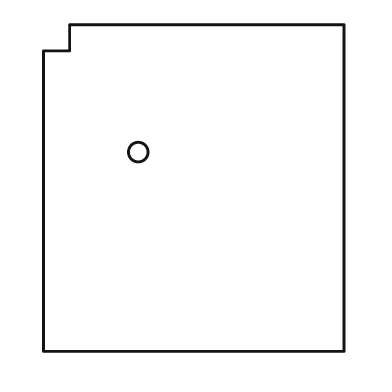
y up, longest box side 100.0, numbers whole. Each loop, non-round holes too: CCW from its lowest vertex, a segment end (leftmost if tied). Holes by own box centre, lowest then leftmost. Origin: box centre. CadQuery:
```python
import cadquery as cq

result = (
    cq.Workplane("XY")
    .moveTo(-46.0, -50.0)
    .lineTo(46.0, -50.0)
    .lineTo(46.0, 50.0)
    .lineTo(-38.0, 50.0)
    .lineTo(-38.0, 42.0)
    .lineTo(-46.0, 42.0)
    .close()
    .moveTo(-17.0, 11.0)
    .circle(3.0)
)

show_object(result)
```